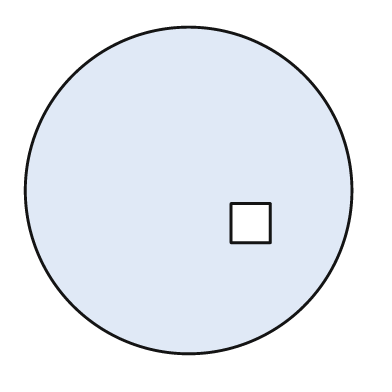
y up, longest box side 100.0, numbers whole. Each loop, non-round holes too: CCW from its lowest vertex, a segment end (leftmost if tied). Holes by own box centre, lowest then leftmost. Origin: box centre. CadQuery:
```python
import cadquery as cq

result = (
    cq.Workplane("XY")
    .moveTo(0.0, 0.0)
    .circle(50.0)
    .moveTo(13.0, -16.0)
    .lineTo(25.0, -16.0)
    .lineTo(25.0, -4.0)
    .lineTo(13.0, -4.0)
    .close()
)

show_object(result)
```